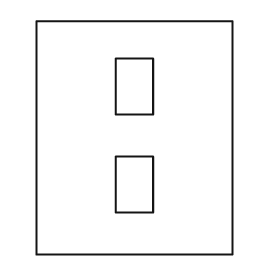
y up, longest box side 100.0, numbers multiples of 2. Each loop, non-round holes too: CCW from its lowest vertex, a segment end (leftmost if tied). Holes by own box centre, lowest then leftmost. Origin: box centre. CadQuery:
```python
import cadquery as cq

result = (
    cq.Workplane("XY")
    .moveTo(-42.0, -50.0)
    .lineTo(42.0, -50.0)
    .lineTo(42.0, 50.0)
    .lineTo(-42.0, 50.0)
    .close()
    .moveTo(-8.0, -32.0)
    .lineTo(8.0, -32.0)
    .lineTo(8.0, -8.0)
    .lineTo(-8.0, -8.0)
    .close()
    .moveTo(-8.0, 10.0)
    .lineTo(8.0, 10.0)
    .lineTo(8.0, 34.0)
    .lineTo(-8.0, 34.0)
    .close()
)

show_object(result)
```